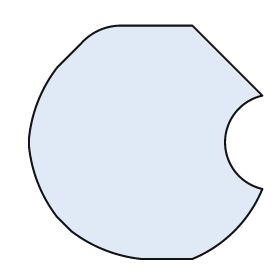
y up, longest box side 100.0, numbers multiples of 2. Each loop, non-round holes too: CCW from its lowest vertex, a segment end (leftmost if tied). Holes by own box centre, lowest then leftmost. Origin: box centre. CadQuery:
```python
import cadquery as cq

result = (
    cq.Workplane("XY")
    .moveTo(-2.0, -50.0)
    .lineTo(20.0, -50.0)
    .threePointArc((38.0, -38.0), (50.0, -20.0))
    .threePointArc((34.0, 0.0), (50.0, 20.0))
    .lineTo(20.0, 50.0)
    .lineTo(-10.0, 50.0)
    .threePointArc((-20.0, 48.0), (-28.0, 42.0))
    .lineTo(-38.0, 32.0)
    .threePointArc((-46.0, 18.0), (-50.0, 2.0))
    .lineTo(-50.0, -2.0)
    .threePointArc((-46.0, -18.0), (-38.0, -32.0))
    .lineTo(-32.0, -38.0)
    .threePointArc((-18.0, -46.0), (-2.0, -50.0))
    .close()
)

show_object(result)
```